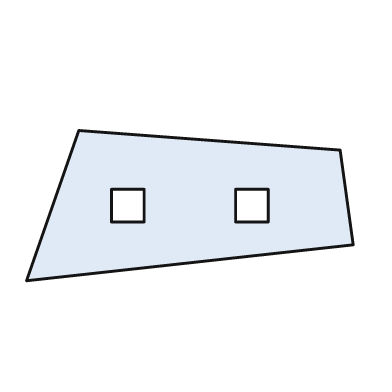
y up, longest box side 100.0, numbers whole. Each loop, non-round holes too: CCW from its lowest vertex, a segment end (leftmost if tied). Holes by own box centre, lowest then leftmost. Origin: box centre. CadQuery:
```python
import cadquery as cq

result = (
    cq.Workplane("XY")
    .moveTo(-50.0, -23.0)
    .lineTo(50.0, -12.0)
    .lineTo(46.0, 17.0)
    .lineTo(-34.0, 23.0)
    .close()
    .moveTo(-24.0, -5.0)
    .lineTo(-14.0, -5.0)
    .lineTo(-14.0, 5.0)
    .lineTo(-24.0, 5.0)
    .close()
    .moveTo(14.0, -5.0)
    .lineTo(24.0, -5.0)
    .lineTo(24.0, 5.0)
    .lineTo(14.0, 5.0)
    .close()
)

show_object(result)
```